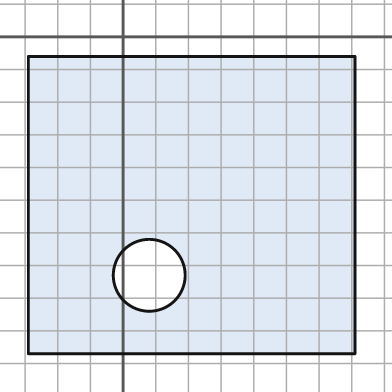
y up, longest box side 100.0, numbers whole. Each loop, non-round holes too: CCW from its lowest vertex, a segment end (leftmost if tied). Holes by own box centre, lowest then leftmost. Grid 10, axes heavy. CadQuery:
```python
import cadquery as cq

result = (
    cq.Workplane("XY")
    .moveTo(-29.0, -97.0)
    .lineTo(71.0, -97.0)
    .lineTo(71.0, -6.0)
    .lineTo(-29.0, -6.0)
    .close()
    .moveTo(8.0, -73.0)
    .circle(11.0)
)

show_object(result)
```